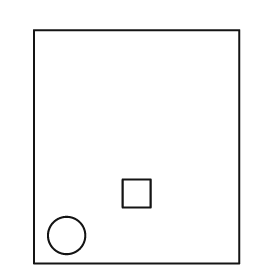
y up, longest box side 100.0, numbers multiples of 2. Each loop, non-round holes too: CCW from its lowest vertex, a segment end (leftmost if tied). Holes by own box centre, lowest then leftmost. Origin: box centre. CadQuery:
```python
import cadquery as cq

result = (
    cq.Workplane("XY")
    .moveTo(-44.0, -50.0)
    .lineTo(44.0, -50.0)
    .lineTo(44.0, 50.0)
    .lineTo(-44.0, 50.0)
    .close()
    .moveTo(-30.0, -38.0)
    .circle(8.0)
    .moveTo(-6.0, -26.0)
    .lineTo(6.0, -26.0)
    .lineTo(6.0, -14.0)
    .lineTo(-6.0, -14.0)
    .close()
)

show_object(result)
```